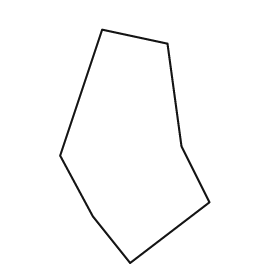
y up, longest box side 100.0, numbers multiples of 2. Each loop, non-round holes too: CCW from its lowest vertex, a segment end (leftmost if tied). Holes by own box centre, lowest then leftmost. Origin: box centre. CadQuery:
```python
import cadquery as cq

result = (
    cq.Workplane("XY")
    .moveTo(-2.0, -50.0)
    .lineTo(32.0, -24.0)
    .lineTo(20.0, 0.0)
    .lineTo(14.0, 44.0)
    .lineTo(-14.0, 50.0)
    .lineTo(-32.0, -4.0)
    .lineTo(-18.0, -30.0)
    .close()
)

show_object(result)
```